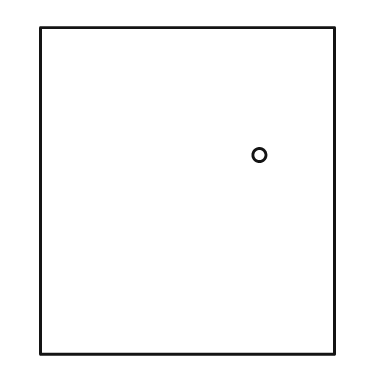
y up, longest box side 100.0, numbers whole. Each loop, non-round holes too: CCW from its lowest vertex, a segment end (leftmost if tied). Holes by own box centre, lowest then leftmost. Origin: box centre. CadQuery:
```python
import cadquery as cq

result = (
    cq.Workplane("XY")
    .moveTo(-45.0, -50.0)
    .lineTo(45.0, -50.0)
    .lineTo(45.0, 50.0)
    .lineTo(-45.0, 50.0)
    .close()
    .moveTo(22.0, 11.0)
    .circle(2.0)
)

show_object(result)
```